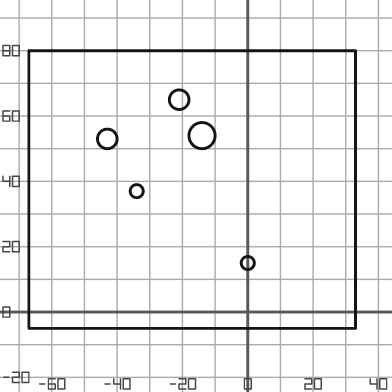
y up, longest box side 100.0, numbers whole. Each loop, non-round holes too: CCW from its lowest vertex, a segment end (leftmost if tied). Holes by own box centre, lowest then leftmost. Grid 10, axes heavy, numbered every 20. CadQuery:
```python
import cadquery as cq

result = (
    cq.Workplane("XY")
    .moveTo(-67.0, -5.0)
    .lineTo(33.0, -5.0)
    .lineTo(33.0, 80.0)
    .lineTo(-67.0, 80.0)
    .close()
    .moveTo(0.0, 15.0)
    .circle(2.0)
    .moveTo(-34.0, 37.0)
    .circle(2.0)
    .moveTo(-43.0, 53.0)
    .circle(3.0)
    .moveTo(-14.0, 54.0)
    .circle(4.0)
    .moveTo(-21.0, 65.0)
    .circle(3.0)
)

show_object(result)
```